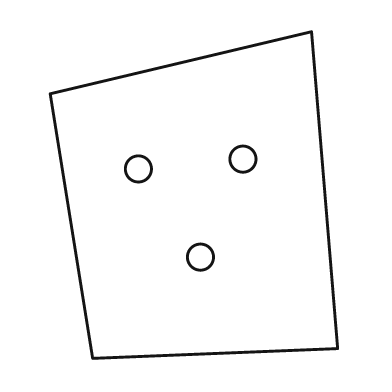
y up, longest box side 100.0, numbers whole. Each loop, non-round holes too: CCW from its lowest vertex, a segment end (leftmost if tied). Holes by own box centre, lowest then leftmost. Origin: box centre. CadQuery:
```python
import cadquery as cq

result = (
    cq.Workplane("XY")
    .moveTo(-31.0, -50.0)
    .lineTo(44.0, -47.0)
    .lineTo(36.0, 50.0)
    .lineTo(-44.0, 31.0)
    .close()
    .moveTo(2.0, -19.0)
    .circle(4.0)
    .moveTo(-17.0, 8.0)
    .circle(4.0)
    .moveTo(15.0, 11.0)
    .circle(4.0)
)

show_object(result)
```